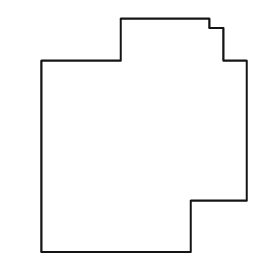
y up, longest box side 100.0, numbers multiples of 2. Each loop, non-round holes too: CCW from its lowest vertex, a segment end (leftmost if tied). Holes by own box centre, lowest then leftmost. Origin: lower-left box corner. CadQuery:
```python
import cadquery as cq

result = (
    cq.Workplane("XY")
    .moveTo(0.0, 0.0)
    .lineTo(64.0, 0.0)
    .lineTo(64.0, 22.0)
    .lineTo(88.0, 22.0)
    .lineTo(88.0, 82.0)
    .lineTo(78.0, 82.0)
    .lineTo(78.0, 96.0)
    .lineTo(72.0, 96.0)
    .lineTo(72.0, 100.0)
    .lineTo(34.0, 100.0)
    .lineTo(34.0, 82.0)
    .lineTo(0.0, 82.0)
    .close()
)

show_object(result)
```